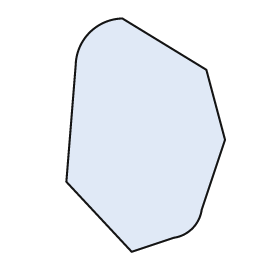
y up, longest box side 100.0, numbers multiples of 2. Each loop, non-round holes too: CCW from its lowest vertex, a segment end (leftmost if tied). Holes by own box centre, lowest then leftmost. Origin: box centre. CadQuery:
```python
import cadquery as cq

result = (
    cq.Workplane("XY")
    .moveTo(-6.0, -50.0)
    .lineTo(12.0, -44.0)
    .threePointArc((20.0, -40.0), (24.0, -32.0))
    .lineTo(34.0, -2.0)
    .lineTo(26.0, 28.0)
    .lineTo(-10.0, 50.0)
    .threePointArc((-24.0, 44.0), (-30.0, 30.0))
    .lineTo(-34.0, -20.0)
    .close()
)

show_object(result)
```